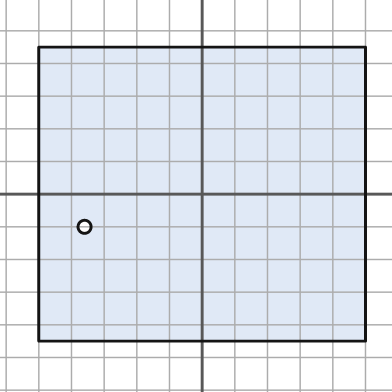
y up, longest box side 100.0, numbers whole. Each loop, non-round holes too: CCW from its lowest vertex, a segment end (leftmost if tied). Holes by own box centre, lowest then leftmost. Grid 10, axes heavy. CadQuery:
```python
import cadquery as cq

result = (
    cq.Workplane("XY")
    .moveTo(-50.0, -45.0)
    .lineTo(50.0, -45.0)
    .lineTo(50.0, 45.0)
    .lineTo(-50.0, 45.0)
    .close()
    .moveTo(-36.0, -10.0)
    .circle(2.0)
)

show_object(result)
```